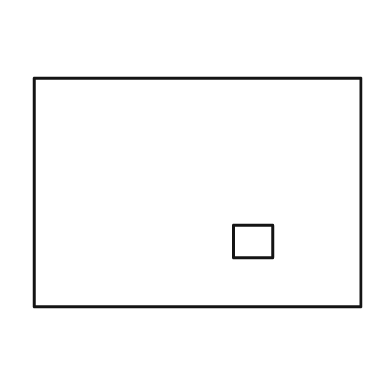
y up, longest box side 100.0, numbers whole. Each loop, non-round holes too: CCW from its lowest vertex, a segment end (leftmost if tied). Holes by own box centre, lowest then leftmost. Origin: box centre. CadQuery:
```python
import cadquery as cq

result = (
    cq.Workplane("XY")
    .moveTo(-50.0, -35.0)
    .lineTo(50.0, -35.0)
    .lineTo(50.0, 35.0)
    .lineTo(-50.0, 35.0)
    .close()
    .moveTo(11.0, -20.0)
    .lineTo(23.0, -20.0)
    .lineTo(23.0, -10.0)
    .lineTo(11.0, -10.0)
    .close()
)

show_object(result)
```